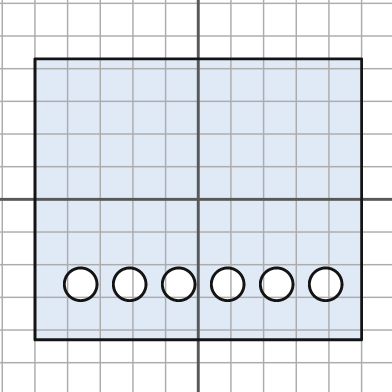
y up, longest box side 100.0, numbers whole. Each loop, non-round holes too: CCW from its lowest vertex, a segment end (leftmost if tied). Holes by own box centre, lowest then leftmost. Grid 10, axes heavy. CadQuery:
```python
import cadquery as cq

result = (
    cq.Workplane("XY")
    .moveTo(-50.0, -43.0)
    .lineTo(50.0, -43.0)
    .lineTo(50.0, 43.0)
    .lineTo(-50.0, 43.0)
    .close()
    .moveTo(-36.0, -26.0)
    .circle(5.0)
    .moveTo(-21.0, -26.0)
    .circle(5.0)
    .moveTo(-6.0, -26.0)
    .circle(5.0)
    .moveTo(9.0, -26.0)
    .circle(5.0)
    .moveTo(24.0, -26.0)
    .circle(5.0)
    .moveTo(39.0, -26.0)
    .circle(5.0)
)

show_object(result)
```